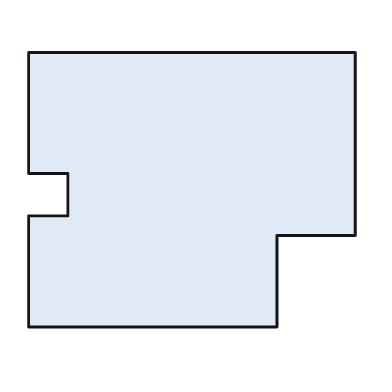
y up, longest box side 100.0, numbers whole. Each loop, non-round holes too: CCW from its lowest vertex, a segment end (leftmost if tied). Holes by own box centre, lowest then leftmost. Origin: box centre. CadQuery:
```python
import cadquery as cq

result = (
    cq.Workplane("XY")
    .moveTo(-50.0, -42.0)
    .lineTo(26.0, -42.0)
    .lineTo(26.0, -14.0)
    .lineTo(50.0, -14.0)
    .lineTo(50.0, 42.0)
    .lineTo(-50.0, 42.0)
    .lineTo(-50.0, 5.0)
    .lineTo(-38.0, 5.0)
    .lineTo(-38.0, -8.0)
    .lineTo(-50.0, -8.0)
    .close()
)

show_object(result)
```